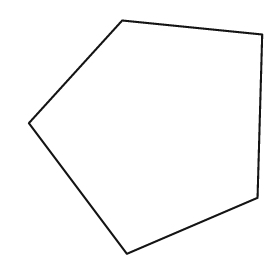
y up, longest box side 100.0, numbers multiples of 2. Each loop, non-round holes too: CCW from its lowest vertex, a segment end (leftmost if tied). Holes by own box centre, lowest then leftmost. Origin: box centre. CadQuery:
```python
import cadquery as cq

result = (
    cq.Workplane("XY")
    .moveTo(-8.0, -50.0)
    .lineTo(48.0, -26.0)
    .lineTo(50.0, 44.0)
    .lineTo(-10.0, 50.0)
    .lineTo(-50.0, 6.0)
    .close()
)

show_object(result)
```